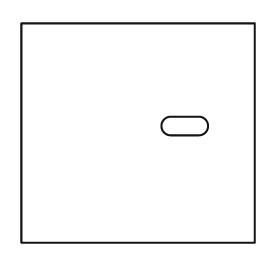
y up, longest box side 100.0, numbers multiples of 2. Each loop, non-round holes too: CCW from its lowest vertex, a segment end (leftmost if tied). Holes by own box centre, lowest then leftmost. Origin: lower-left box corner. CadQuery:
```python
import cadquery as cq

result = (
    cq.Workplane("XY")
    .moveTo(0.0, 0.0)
    .lineTo(100.0, 0.0)
    .lineTo(100.0, 94.0)
    .lineTo(0.0, 94.0)
    .close()
    .moveTo(64.0, 46.0)
    .lineTo(76.0, 46.0)
    .threePointArc((80.0, 50.0), (76.0, 54.0))
    .lineTo(64.0, 54.0)
    .threePointArc((60.0, 50.0), (64.0, 46.0))
    .close()
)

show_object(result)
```